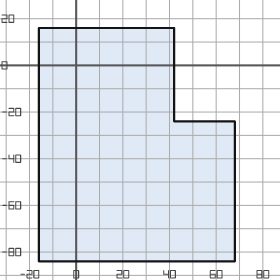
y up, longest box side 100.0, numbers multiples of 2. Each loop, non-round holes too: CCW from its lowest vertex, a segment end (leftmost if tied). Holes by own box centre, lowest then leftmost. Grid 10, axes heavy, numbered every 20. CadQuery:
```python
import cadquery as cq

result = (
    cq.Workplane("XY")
    .moveTo(-16.0, -84.0)
    .lineTo(68.0, -84.0)
    .lineTo(68.0, -24.0)
    .lineTo(42.0, -24.0)
    .lineTo(42.0, 16.0)
    .lineTo(-16.0, 16.0)
    .close()
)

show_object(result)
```